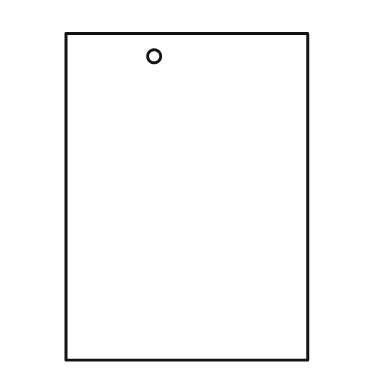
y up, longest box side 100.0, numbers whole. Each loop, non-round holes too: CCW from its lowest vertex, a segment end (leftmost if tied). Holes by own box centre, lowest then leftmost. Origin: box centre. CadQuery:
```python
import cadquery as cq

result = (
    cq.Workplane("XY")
    .moveTo(-37.0, -50.0)
    .lineTo(37.0, -50.0)
    .lineTo(37.0, 50.0)
    .lineTo(-37.0, 50.0)
    .close()
    .moveTo(-10.0, 43.0)
    .circle(2.0)
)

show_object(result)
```